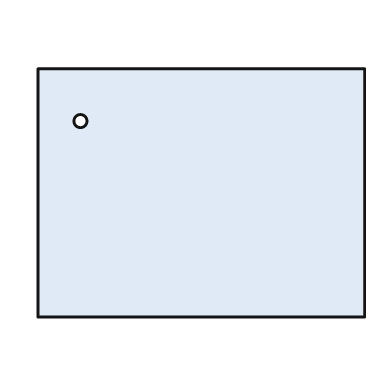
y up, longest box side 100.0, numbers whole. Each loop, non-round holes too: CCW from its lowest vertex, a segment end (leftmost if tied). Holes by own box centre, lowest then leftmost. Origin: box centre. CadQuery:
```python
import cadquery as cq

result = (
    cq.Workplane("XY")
    .moveTo(-50.0, -38.0)
    .lineTo(50.0, -38.0)
    .lineTo(50.0, 38.0)
    .lineTo(-50.0, 38.0)
    .close()
    .moveTo(-37.0, 22.0)
    .circle(2.0)
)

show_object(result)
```